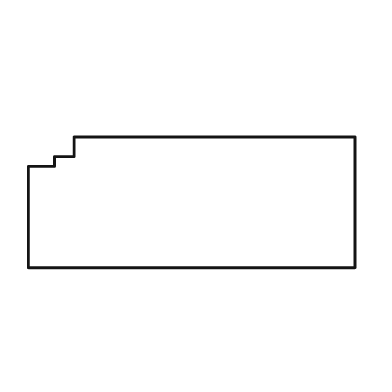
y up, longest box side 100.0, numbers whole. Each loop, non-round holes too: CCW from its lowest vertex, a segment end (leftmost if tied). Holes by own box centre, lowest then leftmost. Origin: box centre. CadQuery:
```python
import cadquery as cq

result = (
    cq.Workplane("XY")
    .moveTo(-50.0, -20.0)
    .lineTo(50.0, -20.0)
    .lineTo(50.0, 20.0)
    .lineTo(-36.0, 20.0)
    .lineTo(-36.0, 14.0)
    .lineTo(-42.0, 14.0)
    .lineTo(-42.0, 11.0)
    .lineTo(-50.0, 11.0)
    .close()
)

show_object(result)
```